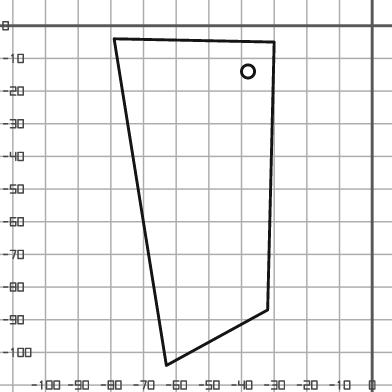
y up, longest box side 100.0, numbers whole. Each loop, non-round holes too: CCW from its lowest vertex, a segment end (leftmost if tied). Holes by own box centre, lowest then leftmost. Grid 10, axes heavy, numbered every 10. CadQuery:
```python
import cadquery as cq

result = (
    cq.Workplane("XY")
    .moveTo(-63.0, -104.0)
    .lineTo(-32.0, -87.0)
    .lineTo(-30.0, -5.0)
    .lineTo(-79.0, -4.0)
    .close()
    .moveTo(-38.0, -14.0)
    .circle(2.0)
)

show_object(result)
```